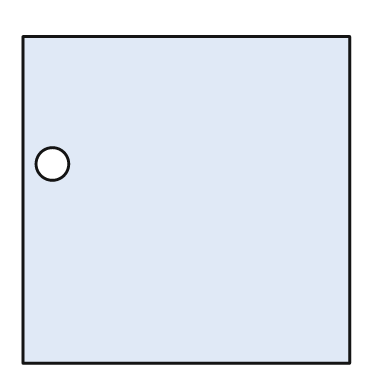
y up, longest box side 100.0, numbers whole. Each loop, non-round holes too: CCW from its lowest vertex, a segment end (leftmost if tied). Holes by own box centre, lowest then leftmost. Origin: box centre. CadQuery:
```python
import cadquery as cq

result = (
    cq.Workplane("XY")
    .moveTo(-50.0, -50.0)
    .lineTo(50.0, -50.0)
    .lineTo(50.0, 50.0)
    .lineTo(-50.0, 50.0)
    .close()
    .moveTo(-41.0, 11.0)
    .circle(5.0)
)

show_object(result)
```